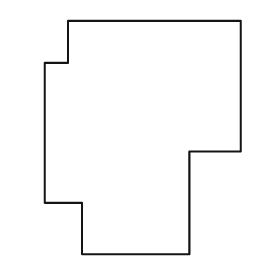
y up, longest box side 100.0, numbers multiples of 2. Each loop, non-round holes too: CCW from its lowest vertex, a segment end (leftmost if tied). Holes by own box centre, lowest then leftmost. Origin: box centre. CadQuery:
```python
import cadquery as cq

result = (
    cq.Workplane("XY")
    .moveTo(-26.0, -50.0)
    .lineTo(20.0, -50.0)
    .lineTo(20.0, -6.0)
    .lineTo(42.0, -6.0)
    .lineTo(42.0, 50.0)
    .lineTo(-32.0, 50.0)
    .lineTo(-32.0, 32.0)
    .lineTo(-42.0, 32.0)
    .lineTo(-42.0, -28.0)
    .lineTo(-26.0, -28.0)
    .close()
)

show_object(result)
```